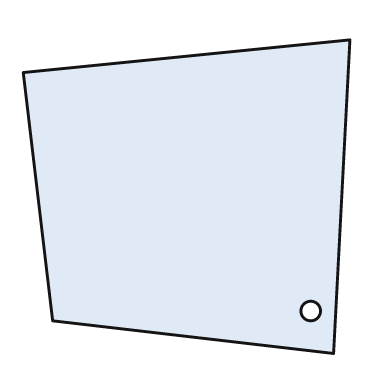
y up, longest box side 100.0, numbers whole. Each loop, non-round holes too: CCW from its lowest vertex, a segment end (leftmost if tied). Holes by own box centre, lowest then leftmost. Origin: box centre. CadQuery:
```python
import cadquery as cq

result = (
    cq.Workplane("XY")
    .moveTo(45.0, -48.0)
    .lineTo(50.0, 48.0)
    .lineTo(-50.0, 38.0)
    .lineTo(-41.0, -38.0)
    .close()
    .moveTo(38.0, -35.0)
    .circle(3.0)
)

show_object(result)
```